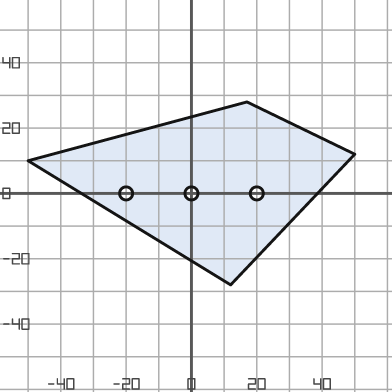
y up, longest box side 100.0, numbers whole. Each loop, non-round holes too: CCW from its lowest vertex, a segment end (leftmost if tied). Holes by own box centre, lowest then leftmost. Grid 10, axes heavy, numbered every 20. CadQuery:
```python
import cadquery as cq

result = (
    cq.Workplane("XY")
    .moveTo(12.0, -28.0)
    .lineTo(50.0, 12.0)
    .lineTo(17.0, 28.0)
    .lineTo(-50.0, 10.0)
    .close()
    .moveTo(-20.0, 0.0)
    .circle(2.0)
    .moveTo(0.0, 0.0)
    .circle(2.0)
    .moveTo(20.0, 0.0)
    .circle(2.0)
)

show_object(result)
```